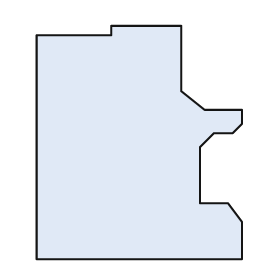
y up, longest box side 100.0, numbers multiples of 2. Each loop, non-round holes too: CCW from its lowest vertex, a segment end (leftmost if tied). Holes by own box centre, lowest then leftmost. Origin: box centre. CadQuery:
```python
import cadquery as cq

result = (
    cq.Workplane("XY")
    .moveTo(-44.0, -50.0)
    .lineTo(44.0, -50.0)
    .lineTo(44.0, -34.0)
    .lineTo(38.0, -26.0)
    .lineTo(26.0, -26.0)
    .lineTo(26.0, -2.0)
    .lineTo(32.0, 4.0)
    .lineTo(40.0, 4.0)
    .lineTo(44.0, 8.0)
    .lineTo(44.0, 14.0)
    .lineTo(28.0, 14.0)
    .lineTo(18.0, 22.0)
    .lineTo(18.0, 50.0)
    .lineTo(-12.0, 50.0)
    .lineTo(-12.0, 46.0)
    .lineTo(-44.0, 46.0)
    .close()
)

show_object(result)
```